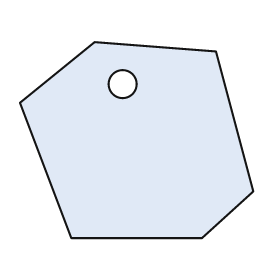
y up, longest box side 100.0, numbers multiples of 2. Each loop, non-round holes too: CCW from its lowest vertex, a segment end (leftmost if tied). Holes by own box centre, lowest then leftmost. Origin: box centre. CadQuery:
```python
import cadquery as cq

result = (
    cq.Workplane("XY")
    .moveTo(-28.0, -42.0)
    .lineTo(28.0, -42.0)
    .lineTo(50.0, -22.0)
    .lineTo(34.0, 38.0)
    .lineTo(-18.0, 42.0)
    .lineTo(-50.0, 16.0)
    .close()
    .moveTo(-6.0, 24.0)
    .circle(6.0)
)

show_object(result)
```